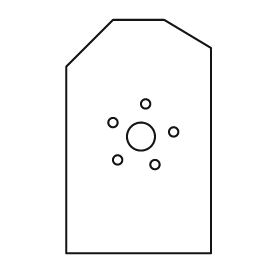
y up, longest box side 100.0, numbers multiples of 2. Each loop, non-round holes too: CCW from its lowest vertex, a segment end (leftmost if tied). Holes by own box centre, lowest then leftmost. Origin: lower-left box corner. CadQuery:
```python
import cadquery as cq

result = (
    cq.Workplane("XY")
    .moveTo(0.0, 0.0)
    .lineTo(62.0, 0.0)
    .lineTo(62.0, 88.0)
    .lineTo(42.0, 100.0)
    .lineTo(20.0, 100.0)
    .lineTo(0.0, 80.0)
    .close()
    .moveTo(38.0, 38.0)
    .circle(2.0)
    .moveTo(22.0, 40.0)
    .circle(2.0)
    .moveTo(32.0, 50.0)
    .circle(6.0)
    .moveTo(46.0, 52.0)
    .circle(2.0)
    .moveTo(20.0, 56.0)
    .circle(2.0)
    .moveTo(34.0, 64.0)
    .circle(2.0)
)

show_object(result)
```